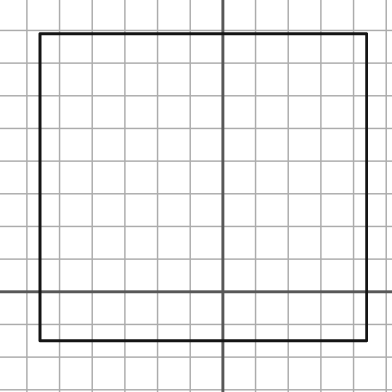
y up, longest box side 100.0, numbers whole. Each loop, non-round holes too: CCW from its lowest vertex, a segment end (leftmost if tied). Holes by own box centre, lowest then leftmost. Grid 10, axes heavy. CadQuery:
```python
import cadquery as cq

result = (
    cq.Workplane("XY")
    .moveTo(-56.0, -15.0)
    .lineTo(44.0, -15.0)
    .lineTo(44.0, 79.0)
    .lineTo(-56.0, 79.0)
    .close()
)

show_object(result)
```